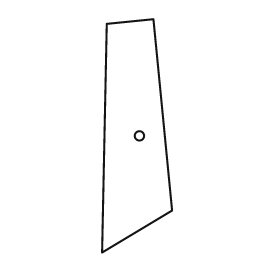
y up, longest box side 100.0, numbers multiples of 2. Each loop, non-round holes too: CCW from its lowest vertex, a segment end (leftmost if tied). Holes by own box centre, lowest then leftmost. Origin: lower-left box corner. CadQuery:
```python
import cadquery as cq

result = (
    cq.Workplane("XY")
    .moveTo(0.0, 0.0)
    .lineTo(30.0, 18.0)
    .lineTo(22.0, 100.0)
    .lineTo(2.0, 98.0)
    .close()
    .moveTo(16.0, 50.0)
    .circle(2.0)
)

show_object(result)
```